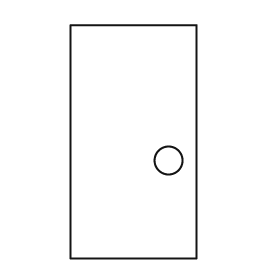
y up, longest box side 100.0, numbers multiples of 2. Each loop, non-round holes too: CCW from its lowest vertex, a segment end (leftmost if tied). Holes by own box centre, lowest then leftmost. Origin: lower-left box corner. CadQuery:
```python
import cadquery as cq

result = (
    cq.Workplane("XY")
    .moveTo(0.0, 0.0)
    .lineTo(54.0, 0.0)
    .lineTo(54.0, 100.0)
    .lineTo(0.0, 100.0)
    .close()
    .moveTo(42.0, 42.0)
    .circle(6.0)
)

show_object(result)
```